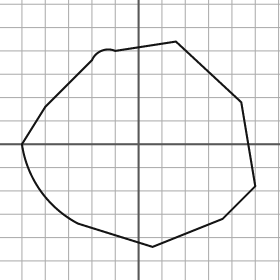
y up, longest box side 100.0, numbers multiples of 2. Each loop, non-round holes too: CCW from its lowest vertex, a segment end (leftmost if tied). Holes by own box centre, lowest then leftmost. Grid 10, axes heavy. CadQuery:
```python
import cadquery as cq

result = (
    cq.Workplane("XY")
    .moveTo(6.0, -44.0)
    .lineTo(36.0, -32.0)
    .lineTo(50.0, -18.0)
    .lineTo(44.0, 18.0)
    .lineTo(16.0, 44.0)
    .lineTo(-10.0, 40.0)
    .threePointArc((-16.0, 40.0), (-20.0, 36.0))
    .lineTo(-40.0, 16.0)
    .lineTo(-50.0, 0.0)
    .threePointArc((-42.0, -20.0), (-26.0, -34.0))
    .close()
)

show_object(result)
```